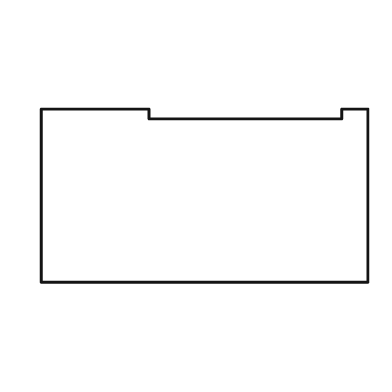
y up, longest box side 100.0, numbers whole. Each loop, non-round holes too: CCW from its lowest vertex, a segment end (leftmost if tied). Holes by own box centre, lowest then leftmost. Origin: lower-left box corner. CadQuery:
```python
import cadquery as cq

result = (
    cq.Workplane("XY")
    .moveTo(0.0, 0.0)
    .lineTo(100.0, 0.0)
    .lineTo(100.0, 53.0)
    .lineTo(92.0, 53.0)
    .lineTo(92.0, 50.0)
    .lineTo(33.0, 50.0)
    .lineTo(33.0, 53.0)
    .lineTo(0.0, 53.0)
    .close()
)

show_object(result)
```